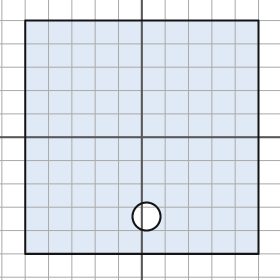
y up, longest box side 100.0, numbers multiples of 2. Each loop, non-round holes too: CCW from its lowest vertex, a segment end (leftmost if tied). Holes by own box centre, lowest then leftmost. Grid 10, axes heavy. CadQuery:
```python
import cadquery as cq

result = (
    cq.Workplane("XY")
    .moveTo(-50.0, -50.0)
    .lineTo(50.0, -50.0)
    .lineTo(50.0, 50.0)
    .lineTo(-50.0, 50.0)
    .close()
    .moveTo(2.0, -34.0)
    .circle(6.0)
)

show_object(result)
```